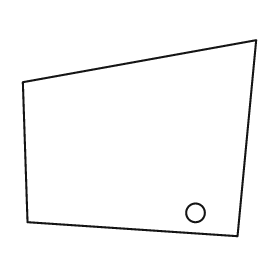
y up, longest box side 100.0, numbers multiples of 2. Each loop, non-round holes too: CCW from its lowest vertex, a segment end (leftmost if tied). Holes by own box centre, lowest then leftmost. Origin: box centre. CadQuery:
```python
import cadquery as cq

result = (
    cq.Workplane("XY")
    .moveTo(42.0, -42.0)
    .lineTo(50.0, 42.0)
    .lineTo(-50.0, 24.0)
    .lineTo(-48.0, -36.0)
    .close()
    .moveTo(24.0, -32.0)
    .circle(4.0)
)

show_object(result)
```